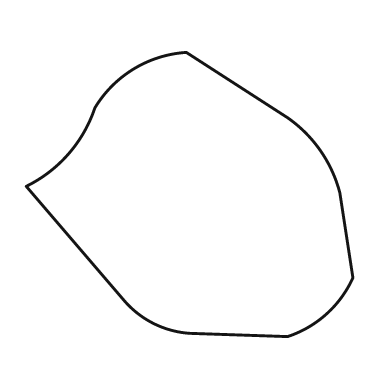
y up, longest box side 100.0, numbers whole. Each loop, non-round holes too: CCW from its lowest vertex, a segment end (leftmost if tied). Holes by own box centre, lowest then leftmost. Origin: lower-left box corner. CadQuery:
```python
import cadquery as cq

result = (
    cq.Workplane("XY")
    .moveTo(80.0, 0.0)
    .threePointArc((92.0, 7.0), (100.0, 18.0))
    .lineTo(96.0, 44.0)
    .threePointArc((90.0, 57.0), (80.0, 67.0))
    .lineTo(49.0, 87.0)
    .threePointArc((33.0, 82.0), (21.0, 70.0))
    .threePointArc((13.0, 56.0), (0.0, 46.0))
    .lineTo(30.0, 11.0)
    .threePointArc((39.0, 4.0), (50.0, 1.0))
    .close()
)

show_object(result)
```